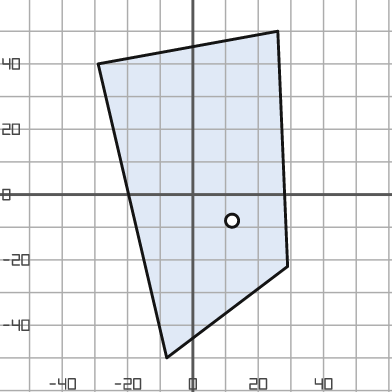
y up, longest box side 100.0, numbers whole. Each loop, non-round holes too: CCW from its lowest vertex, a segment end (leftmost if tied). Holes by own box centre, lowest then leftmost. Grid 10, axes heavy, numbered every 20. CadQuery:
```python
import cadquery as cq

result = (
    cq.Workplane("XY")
    .moveTo(-8.0, -50.0)
    .lineTo(29.0, -22.0)
    .lineTo(26.0, 50.0)
    .lineTo(-29.0, 40.0)
    .close()
    .moveTo(12.0, -8.0)
    .circle(2.0)
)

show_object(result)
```